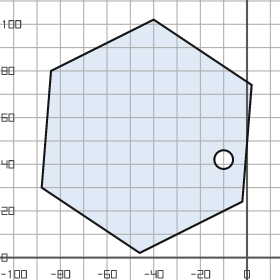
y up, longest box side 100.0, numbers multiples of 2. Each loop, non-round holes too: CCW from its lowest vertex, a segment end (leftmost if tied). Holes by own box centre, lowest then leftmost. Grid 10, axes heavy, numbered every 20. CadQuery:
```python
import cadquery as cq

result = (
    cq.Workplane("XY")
    .moveTo(-46.0, 2.0)
    .lineTo(-2.0, 24.0)
    .lineTo(2.0, 74.0)
    .lineTo(-40.0, 102.0)
    .lineTo(-84.0, 80.0)
    .lineTo(-88.0, 30.0)
    .close()
    .moveTo(-10.0, 42.0)
    .circle(4.0)
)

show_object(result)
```